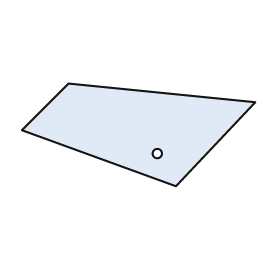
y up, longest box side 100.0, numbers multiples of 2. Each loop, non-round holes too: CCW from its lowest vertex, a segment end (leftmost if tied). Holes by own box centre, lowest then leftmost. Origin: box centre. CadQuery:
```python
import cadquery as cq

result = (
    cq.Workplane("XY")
    .moveTo(16.0, -22.0)
    .lineTo(50.0, 14.0)
    .lineTo(-30.0, 22.0)
    .lineTo(-50.0, 2.0)
    .close()
    .moveTo(8.0, -8.0)
    .circle(2.0)
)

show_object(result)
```